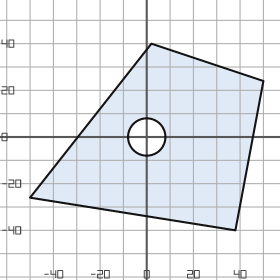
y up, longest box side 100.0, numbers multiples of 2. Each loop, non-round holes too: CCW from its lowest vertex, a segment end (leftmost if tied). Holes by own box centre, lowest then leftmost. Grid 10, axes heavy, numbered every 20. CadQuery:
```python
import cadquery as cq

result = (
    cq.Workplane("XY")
    .moveTo(38.0, -40.0)
    .lineTo(50.0, 24.0)
    .lineTo(2.0, 40.0)
    .lineTo(-50.0, -26.0)
    .close()
    .moveTo(0.0, 0.0)
    .circle(8.0)
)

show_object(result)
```